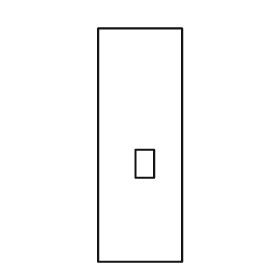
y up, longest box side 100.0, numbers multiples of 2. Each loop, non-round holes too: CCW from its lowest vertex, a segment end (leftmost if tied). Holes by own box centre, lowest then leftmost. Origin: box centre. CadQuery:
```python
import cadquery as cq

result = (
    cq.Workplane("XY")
    .moveTo(-18.0, -50.0)
    .lineTo(18.0, -50.0)
    .lineTo(18.0, 50.0)
    .lineTo(-18.0, 50.0)
    .close()
    .moveTo(-2.0, -14.0)
    .lineTo(6.0, -14.0)
    .lineTo(6.0, -2.0)
    .lineTo(-2.0, -2.0)
    .close()
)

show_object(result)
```